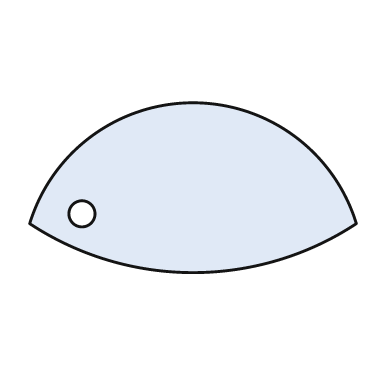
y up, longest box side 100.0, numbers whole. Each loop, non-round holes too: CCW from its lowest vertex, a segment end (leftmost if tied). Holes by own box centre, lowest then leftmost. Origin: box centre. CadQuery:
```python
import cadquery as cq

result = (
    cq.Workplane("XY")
    .moveTo(-50.0, -11.0)
    .threePointArc((0.0, -26.0), (50.0, -11.0))
    .threePointArc((0.0, 26.0), (-50.0, -11.0))
    .close()
    .moveTo(-34.0, -8.0)
    .circle(4.0)
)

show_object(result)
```